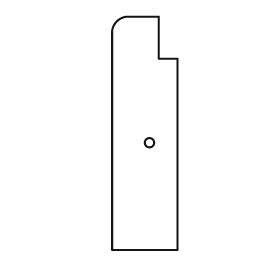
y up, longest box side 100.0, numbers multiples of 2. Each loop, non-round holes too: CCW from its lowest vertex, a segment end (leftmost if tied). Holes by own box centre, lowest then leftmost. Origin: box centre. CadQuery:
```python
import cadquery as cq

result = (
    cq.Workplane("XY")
    .moveTo(-14.0, -50.0)
    .lineTo(14.0, -50.0)
    .lineTo(14.0, 32.0)
    .lineTo(6.0, 32.0)
    .lineTo(6.0, 50.0)
    .lineTo(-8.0, 50.0)
    .threePointArc((-12.0, 48.0), (-14.0, 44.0))
    .close()
    .moveTo(2.0, -4.0)
    .circle(2.0)
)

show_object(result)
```